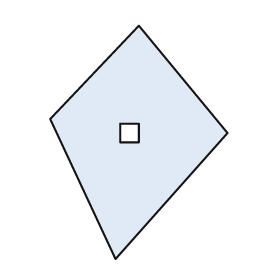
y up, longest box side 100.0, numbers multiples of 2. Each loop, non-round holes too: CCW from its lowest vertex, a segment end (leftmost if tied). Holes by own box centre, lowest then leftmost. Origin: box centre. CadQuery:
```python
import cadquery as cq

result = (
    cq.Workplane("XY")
    .moveTo(-10.0, -50.0)
    .lineTo(38.0, 4.0)
    .lineTo(0.0, 50.0)
    .lineTo(-38.0, 10.0)
    .close()
    .moveTo(-8.0, 0.0)
    .lineTo(0.0, 0.0)
    .lineTo(0.0, 8.0)
    .lineTo(-8.0, 8.0)
    .close()
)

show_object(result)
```